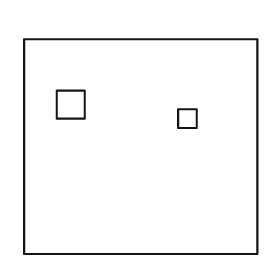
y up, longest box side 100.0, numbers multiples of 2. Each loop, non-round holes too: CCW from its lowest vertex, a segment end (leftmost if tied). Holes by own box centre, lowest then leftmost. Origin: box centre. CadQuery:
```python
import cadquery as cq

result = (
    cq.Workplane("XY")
    .moveTo(-50.0, -46.0)
    .lineTo(50.0, -46.0)
    .lineTo(50.0, 46.0)
    .lineTo(-50.0, 46.0)
    .close()
    .moveTo(16.0, 8.0)
    .lineTo(24.0, 8.0)
    .lineTo(24.0, 16.0)
    .lineTo(16.0, 16.0)
    .close()
    .moveTo(-36.0, 12.0)
    .lineTo(-24.0, 12.0)
    .lineTo(-24.0, 24.0)
    .lineTo(-36.0, 24.0)
    .close()
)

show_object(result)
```